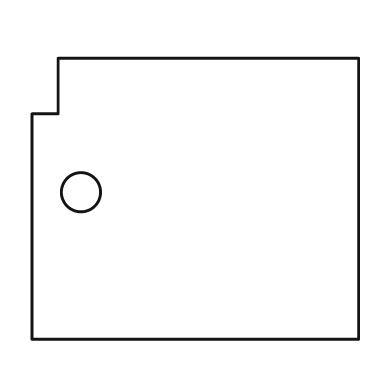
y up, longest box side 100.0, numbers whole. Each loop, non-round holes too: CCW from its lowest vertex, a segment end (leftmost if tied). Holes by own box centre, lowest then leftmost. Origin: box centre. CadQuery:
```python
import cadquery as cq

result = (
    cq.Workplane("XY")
    .moveTo(-50.0, -43.0)
    .lineTo(50.0, -43.0)
    .lineTo(50.0, 43.0)
    .lineTo(-42.0, 43.0)
    .lineTo(-42.0, 26.0)
    .lineTo(-50.0, 26.0)
    .close()
    .moveTo(-35.0, 2.0)
    .circle(6.0)
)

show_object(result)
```